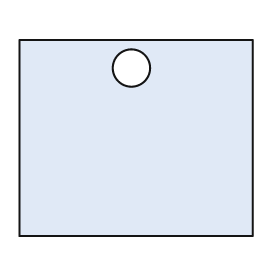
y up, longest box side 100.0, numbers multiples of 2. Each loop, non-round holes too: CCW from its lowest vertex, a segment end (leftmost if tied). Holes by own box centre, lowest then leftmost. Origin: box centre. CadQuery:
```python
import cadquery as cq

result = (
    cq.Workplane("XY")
    .moveTo(-50.0, -42.0)
    .lineTo(50.0, -42.0)
    .lineTo(50.0, 42.0)
    .lineTo(-50.0, 42.0)
    .close()
    .moveTo(-2.0, 30.0)
    .circle(8.0)
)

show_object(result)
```